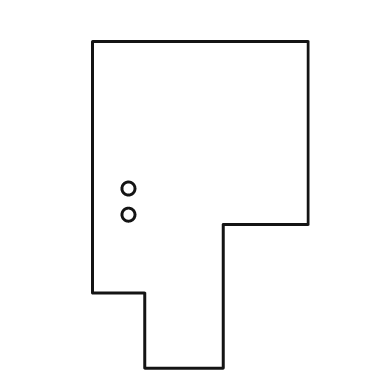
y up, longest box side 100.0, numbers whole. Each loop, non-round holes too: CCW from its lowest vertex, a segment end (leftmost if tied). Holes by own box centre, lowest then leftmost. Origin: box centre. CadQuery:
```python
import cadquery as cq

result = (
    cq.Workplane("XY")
    .moveTo(-17.0, -50.0)
    .lineTo(7.0, -50.0)
    .lineTo(7.0, -6.0)
    .lineTo(33.0, -6.0)
    .lineTo(33.0, 50.0)
    .lineTo(-33.0, 50.0)
    .lineTo(-33.0, -27.0)
    .lineTo(-17.0, -27.0)
    .close()
    .moveTo(-22.0, -3.0)
    .circle(2.0)
    .moveTo(-22.0, 5.0)
    .circle(2.0)
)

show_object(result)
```